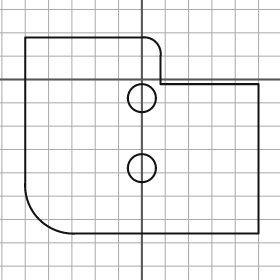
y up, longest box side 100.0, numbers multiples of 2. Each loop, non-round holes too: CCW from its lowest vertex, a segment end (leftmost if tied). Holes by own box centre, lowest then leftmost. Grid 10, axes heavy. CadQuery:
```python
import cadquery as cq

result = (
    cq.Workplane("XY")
    .moveTo(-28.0, -66.0)
    .lineTo(50.0, -66.0)
    .lineTo(50.0, -2.0)
    .lineTo(8.0, -2.0)
    .lineTo(8.0, 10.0)
    .threePointArc((6.0, 16.0), (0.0, 18.0))
    .lineTo(-50.0, 18.0)
    .lineTo(-50.0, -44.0)
    .threePointArc((-44.0, -60.0), (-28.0, -66.0))
    .close()
    .moveTo(0.0, -38.0)
    .circle(6.0)
    .moveTo(0.0, -8.0)
    .circle(6.0)
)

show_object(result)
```